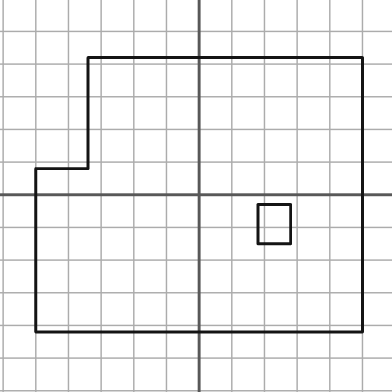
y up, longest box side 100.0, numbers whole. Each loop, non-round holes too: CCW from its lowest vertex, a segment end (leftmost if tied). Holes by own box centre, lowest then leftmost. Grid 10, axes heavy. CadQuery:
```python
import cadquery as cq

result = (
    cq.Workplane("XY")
    .moveTo(-50.0, -42.0)
    .lineTo(50.0, -42.0)
    .lineTo(50.0, 42.0)
    .lineTo(-34.0, 42.0)
    .lineTo(-34.0, 8.0)
    .lineTo(-50.0, 8.0)
    .close()
    .moveTo(18.0, -15.0)
    .lineTo(28.0, -15.0)
    .lineTo(28.0, -3.0)
    .lineTo(18.0, -3.0)
    .close()
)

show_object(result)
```